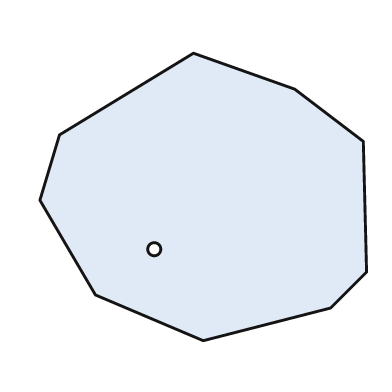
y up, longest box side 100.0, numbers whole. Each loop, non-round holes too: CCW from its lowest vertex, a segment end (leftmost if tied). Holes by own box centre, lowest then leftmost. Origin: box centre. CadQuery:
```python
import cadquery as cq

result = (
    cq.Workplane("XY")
    .moveTo(0.0, -44.0)
    .lineTo(39.0, -34.0)
    .lineTo(50.0, -23.0)
    .lineTo(49.0, 17.0)
    .lineTo(28.0, 33.0)
    .lineTo(-3.0, 44.0)
    .lineTo(-44.0, 19.0)
    .lineTo(-50.0, -1.0)
    .lineTo(-33.0, -30.0)
    .close()
    .moveTo(-15.0, -16.0)
    .circle(2.0)
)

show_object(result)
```